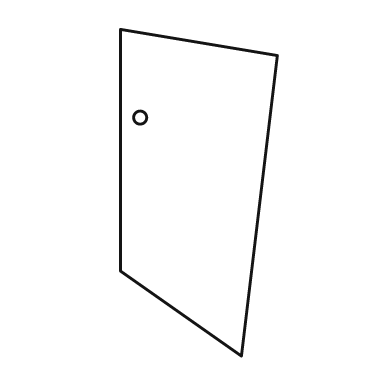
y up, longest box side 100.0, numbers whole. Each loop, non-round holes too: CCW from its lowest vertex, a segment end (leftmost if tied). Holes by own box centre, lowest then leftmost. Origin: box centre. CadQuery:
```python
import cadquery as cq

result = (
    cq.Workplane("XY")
    .moveTo(13.0, -50.0)
    .lineTo(24.0, 42.0)
    .lineTo(-24.0, 50.0)
    .lineTo(-24.0, -24.0)
    .close()
    .moveTo(-18.0, 23.0)
    .circle(2.0)
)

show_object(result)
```